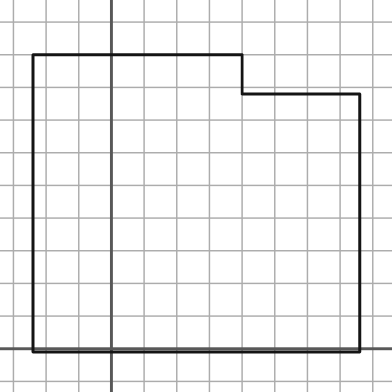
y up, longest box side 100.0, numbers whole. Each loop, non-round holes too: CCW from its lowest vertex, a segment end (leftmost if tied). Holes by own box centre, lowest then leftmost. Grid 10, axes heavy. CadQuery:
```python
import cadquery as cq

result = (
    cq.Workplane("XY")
    .moveTo(-24.0, -1.0)
    .lineTo(76.0, -1.0)
    .lineTo(76.0, 78.0)
    .lineTo(40.0, 78.0)
    .lineTo(40.0, 90.0)
    .lineTo(-24.0, 90.0)
    .close()
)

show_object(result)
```